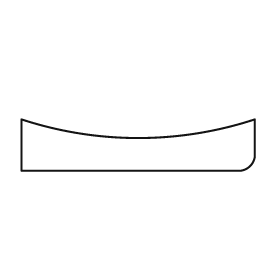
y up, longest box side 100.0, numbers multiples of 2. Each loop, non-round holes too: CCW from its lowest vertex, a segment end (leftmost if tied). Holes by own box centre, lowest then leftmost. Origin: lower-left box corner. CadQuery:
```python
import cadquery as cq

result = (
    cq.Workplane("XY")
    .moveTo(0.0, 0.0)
    .lineTo(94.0, 0.0)
    .threePointArc((98.0, 2.0), (100.0, 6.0))
    .lineTo(100.0, 22.0)
    .threePointArc((50.0, 14.0), (0.0, 22.0))
    .close()
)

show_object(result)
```